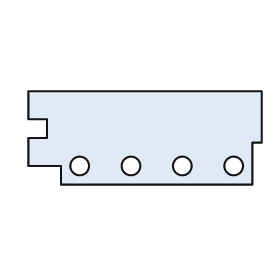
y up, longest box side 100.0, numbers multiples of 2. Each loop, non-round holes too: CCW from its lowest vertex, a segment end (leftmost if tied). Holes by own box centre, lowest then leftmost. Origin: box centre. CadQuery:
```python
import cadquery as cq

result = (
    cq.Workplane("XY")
    .moveTo(-36.0, -20.0)
    .lineTo(46.0, -20.0)
    .lineTo(46.0, -2.0)
    .lineTo(50.0, -2.0)
    .lineTo(50.0, 20.0)
    .lineTo(-50.0, 20.0)
    .lineTo(-50.0, 8.0)
    .lineTo(-42.0, 8.0)
    .lineTo(-42.0, 0.0)
    .lineTo(-50.0, 0.0)
    .lineTo(-50.0, -12.0)
    .lineTo(-36.0, -12.0)
    .close()
    .moveTo(-28.0, -12.0)
    .circle(4.0)
    .moveTo(-6.0, -12.0)
    .circle(4.0)
    .moveTo(16.0, -12.0)
    .circle(4.0)
    .moveTo(38.0, -12.0)
    .circle(4.0)
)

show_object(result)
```